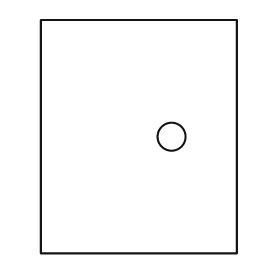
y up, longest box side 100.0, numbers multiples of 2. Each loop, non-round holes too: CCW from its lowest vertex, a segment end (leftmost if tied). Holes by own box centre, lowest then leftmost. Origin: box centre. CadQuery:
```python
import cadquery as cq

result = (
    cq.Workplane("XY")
    .moveTo(-42.0, -50.0)
    .lineTo(42.0, -50.0)
    .lineTo(42.0, 50.0)
    .lineTo(-42.0, 50.0)
    .close()
    .moveTo(14.0, 0.0)
    .circle(6.0)
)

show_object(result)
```